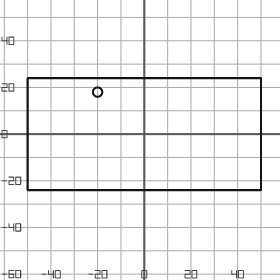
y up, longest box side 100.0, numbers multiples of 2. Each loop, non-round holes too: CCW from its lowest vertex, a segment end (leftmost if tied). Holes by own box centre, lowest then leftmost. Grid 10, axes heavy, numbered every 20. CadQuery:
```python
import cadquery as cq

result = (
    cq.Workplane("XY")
    .moveTo(-50.0, -24.0)
    .lineTo(50.0, -24.0)
    .lineTo(50.0, 24.0)
    .lineTo(-50.0, 24.0)
    .close()
    .moveTo(-20.0, 18.0)
    .circle(2.0)
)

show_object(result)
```